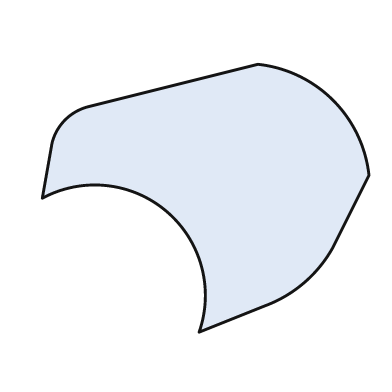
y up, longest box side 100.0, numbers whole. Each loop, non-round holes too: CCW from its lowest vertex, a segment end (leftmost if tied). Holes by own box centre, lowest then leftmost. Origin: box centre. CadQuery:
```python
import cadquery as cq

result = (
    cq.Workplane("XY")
    .moveTo(-2.0, -41.0)
    .lineTo(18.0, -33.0)
    .threePointArc((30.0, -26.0), (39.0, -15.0))
    .lineTo(50.0, 7.0)
    .threePointArc((39.0, 30.0), (16.0, 41.0))
    .lineTo(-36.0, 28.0)
    .threePointArc((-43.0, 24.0), (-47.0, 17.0))
    .lineTo(-50.0, 0.0)
    .threePointArc((-12.0, -4.0), (-2.0, -41.0))
    .close()
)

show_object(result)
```